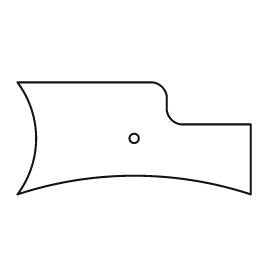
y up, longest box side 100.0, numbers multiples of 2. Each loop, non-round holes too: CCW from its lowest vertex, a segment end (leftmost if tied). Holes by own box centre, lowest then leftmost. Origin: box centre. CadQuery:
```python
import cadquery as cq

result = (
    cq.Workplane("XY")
    .moveTo(-50.0, -24.0)
    .threePointArc((0.0, -16.0), (50.0, -24.0))
    .lineTo(50.0, 6.0)
    .lineTo(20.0, 6.0)
    .threePointArc((16.0, 8.0), (14.0, 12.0))
    .lineTo(14.0, 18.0)
    .threePointArc((12.0, 22.0), (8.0, 24.0))
    .lineTo(-50.0, 24.0)
    .threePointArc((-42.0, 0.0), (-50.0, -24.0))
    .close()
    .moveTo(0.0, 0.0)
    .circle(2.0)
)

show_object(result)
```